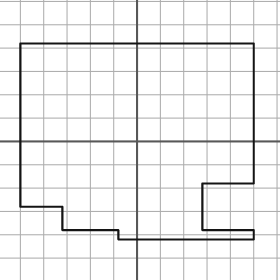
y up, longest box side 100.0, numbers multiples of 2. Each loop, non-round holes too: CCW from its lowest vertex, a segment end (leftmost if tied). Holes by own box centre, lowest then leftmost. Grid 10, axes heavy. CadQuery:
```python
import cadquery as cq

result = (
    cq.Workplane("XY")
    .moveTo(-8.0, -42.0)
    .lineTo(50.0, -42.0)
    .lineTo(50.0, -38.0)
    .lineTo(28.0, -38.0)
    .lineTo(28.0, -18.0)
    .lineTo(50.0, -18.0)
    .lineTo(50.0, 42.0)
    .lineTo(-50.0, 42.0)
    .lineTo(-50.0, -28.0)
    .lineTo(-32.0, -28.0)
    .lineTo(-32.0, -38.0)
    .lineTo(-8.0, -38.0)
    .close()
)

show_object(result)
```